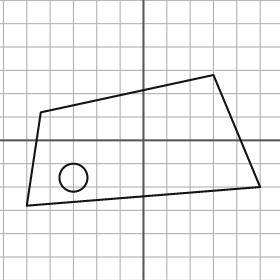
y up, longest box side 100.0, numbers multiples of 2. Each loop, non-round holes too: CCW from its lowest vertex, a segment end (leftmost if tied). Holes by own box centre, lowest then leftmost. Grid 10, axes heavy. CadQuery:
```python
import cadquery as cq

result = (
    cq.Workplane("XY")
    .moveTo(-50.0, -28.0)
    .lineTo(50.0, -20.0)
    .lineTo(30.0, 28.0)
    .lineTo(-44.0, 12.0)
    .close()
    .moveTo(-30.0, -16.0)
    .circle(6.0)
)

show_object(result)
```